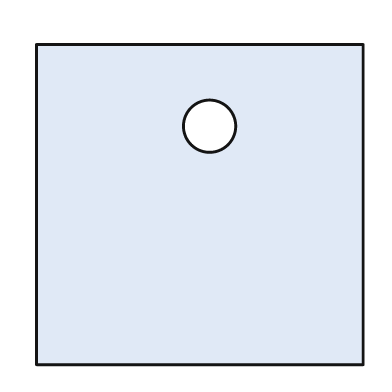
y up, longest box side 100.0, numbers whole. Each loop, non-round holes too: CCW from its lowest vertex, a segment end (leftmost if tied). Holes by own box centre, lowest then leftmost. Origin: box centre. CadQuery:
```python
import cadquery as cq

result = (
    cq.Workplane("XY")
    .moveTo(-50.0, -49.0)
    .lineTo(50.0, -49.0)
    .lineTo(50.0, 49.0)
    .lineTo(-50.0, 49.0)
    .close()
    .moveTo(3.0, 24.0)
    .circle(8.0)
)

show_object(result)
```